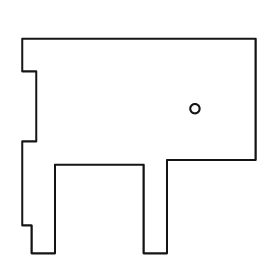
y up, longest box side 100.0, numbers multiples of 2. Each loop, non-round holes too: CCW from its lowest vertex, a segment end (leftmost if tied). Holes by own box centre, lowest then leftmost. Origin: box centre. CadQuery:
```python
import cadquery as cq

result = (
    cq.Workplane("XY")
    .moveTo(-46.0, -46.0)
    .lineTo(-36.0, -46.0)
    .lineTo(-36.0, -8.0)
    .lineTo(2.0, -8.0)
    .lineTo(2.0, -46.0)
    .lineTo(12.0, -46.0)
    .lineTo(12.0, -6.0)
    .lineTo(50.0, -6.0)
    .lineTo(50.0, 46.0)
    .lineTo(-50.0, 46.0)
    .lineTo(-50.0, 32.0)
    .lineTo(-44.0, 32.0)
    .lineTo(-44.0, 2.0)
    .lineTo(-50.0, 2.0)
    .lineTo(-50.0, -34.0)
    .lineTo(-46.0, -34.0)
    .close()
    .moveTo(24.0, 16.0)
    .circle(2.0)
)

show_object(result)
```